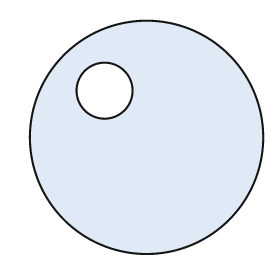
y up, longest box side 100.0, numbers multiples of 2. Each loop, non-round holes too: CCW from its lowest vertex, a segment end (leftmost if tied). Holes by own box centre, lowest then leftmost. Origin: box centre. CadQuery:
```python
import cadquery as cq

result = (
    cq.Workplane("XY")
    .moveTo(0.0, 0.0)
    .circle(50.0)
    .moveTo(-18.0, 20.0)
    .circle(12.0)
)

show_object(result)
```